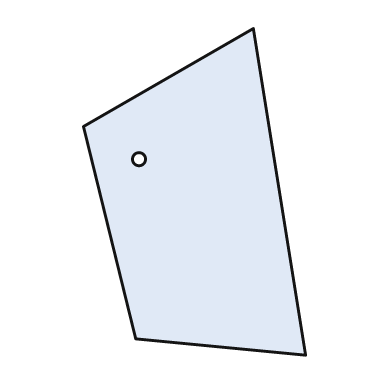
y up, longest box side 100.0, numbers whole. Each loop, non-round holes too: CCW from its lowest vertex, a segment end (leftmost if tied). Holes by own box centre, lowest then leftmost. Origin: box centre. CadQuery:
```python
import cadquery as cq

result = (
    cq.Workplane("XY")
    .moveTo(34.0, -50.0)
    .lineTo(18.0, 50.0)
    .lineTo(-34.0, 20.0)
    .lineTo(-18.0, -45.0)
    .close()
    .moveTo(-17.0, 10.0)
    .circle(2.0)
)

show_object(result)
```